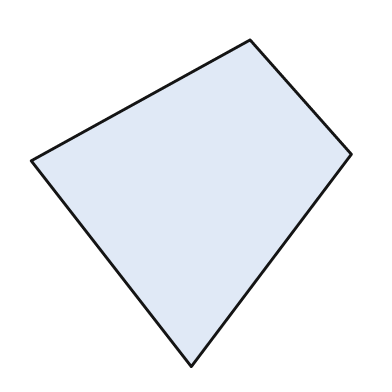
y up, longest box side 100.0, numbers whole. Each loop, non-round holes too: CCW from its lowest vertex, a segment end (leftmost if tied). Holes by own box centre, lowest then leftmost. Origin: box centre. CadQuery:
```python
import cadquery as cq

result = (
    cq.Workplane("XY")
    .moveTo(0.0, -50.0)
    .lineTo(49.0, 15.0)
    .lineTo(18.0, 50.0)
    .lineTo(-49.0, 13.0)
    .close()
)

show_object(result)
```